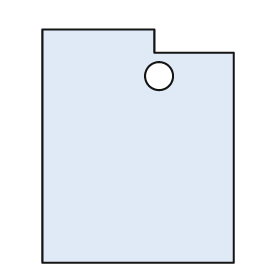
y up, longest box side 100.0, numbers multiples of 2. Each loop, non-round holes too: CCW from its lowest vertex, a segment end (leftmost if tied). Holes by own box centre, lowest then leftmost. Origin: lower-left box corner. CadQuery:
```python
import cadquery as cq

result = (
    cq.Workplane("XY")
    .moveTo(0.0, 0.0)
    .lineTo(82.0, 0.0)
    .lineTo(82.0, 90.0)
    .lineTo(48.0, 90.0)
    .lineTo(48.0, 100.0)
    .lineTo(0.0, 100.0)
    .close()
    .moveTo(50.0, 80.0)
    .circle(6.0)
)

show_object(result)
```